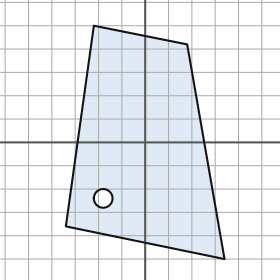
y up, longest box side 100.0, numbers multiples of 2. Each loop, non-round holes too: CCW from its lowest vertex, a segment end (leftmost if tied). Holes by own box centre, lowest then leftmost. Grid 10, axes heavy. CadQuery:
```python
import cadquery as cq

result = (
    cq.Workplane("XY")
    .moveTo(34.0, -50.0)
    .lineTo(18.0, 42.0)
    .lineTo(-22.0, 50.0)
    .lineTo(-34.0, -36.0)
    .close()
    .moveTo(-18.0, -24.0)
    .circle(4.0)
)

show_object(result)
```